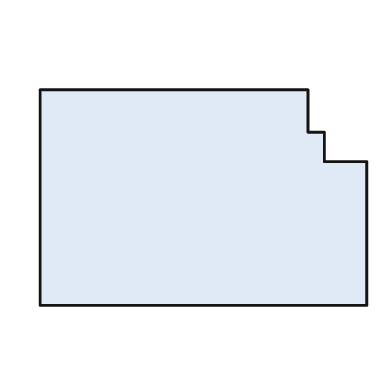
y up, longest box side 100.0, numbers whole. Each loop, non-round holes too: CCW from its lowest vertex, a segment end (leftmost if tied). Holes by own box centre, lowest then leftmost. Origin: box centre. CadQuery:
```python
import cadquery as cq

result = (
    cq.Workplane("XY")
    .moveTo(-50.0, -33.0)
    .lineTo(50.0, -33.0)
    .lineTo(50.0, 11.0)
    .lineTo(37.0, 11.0)
    .lineTo(37.0, 20.0)
    .lineTo(32.0, 20.0)
    .lineTo(32.0, 33.0)
    .lineTo(-50.0, 33.0)
    .close()
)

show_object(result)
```